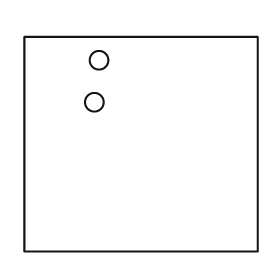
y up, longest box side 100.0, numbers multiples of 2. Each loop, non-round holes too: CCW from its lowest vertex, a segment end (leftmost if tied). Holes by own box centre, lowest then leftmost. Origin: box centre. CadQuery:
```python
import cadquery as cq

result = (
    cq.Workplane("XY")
    .moveTo(-50.0, -46.0)
    .lineTo(50.0, -46.0)
    .lineTo(50.0, 46.0)
    .lineTo(-50.0, 46.0)
    .close()
    .moveTo(-20.0, 18.0)
    .circle(4.0)
    .moveTo(-18.0, 36.0)
    .circle(4.0)
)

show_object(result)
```